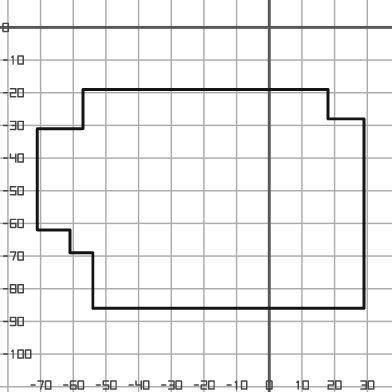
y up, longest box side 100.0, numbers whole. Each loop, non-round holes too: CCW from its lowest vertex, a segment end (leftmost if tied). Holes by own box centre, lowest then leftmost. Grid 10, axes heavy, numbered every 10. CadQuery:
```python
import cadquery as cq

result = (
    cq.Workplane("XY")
    .moveTo(-54.0, -86.0)
    .lineTo(29.0, -86.0)
    .lineTo(29.0, -28.0)
    .lineTo(18.0, -28.0)
    .lineTo(18.0, -19.0)
    .lineTo(-57.0, -19.0)
    .lineTo(-57.0, -31.0)
    .lineTo(-71.0, -31.0)
    .lineTo(-71.0, -62.0)
    .lineTo(-61.0, -62.0)
    .lineTo(-61.0, -69.0)
    .lineTo(-54.0, -69.0)
    .close()
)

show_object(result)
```